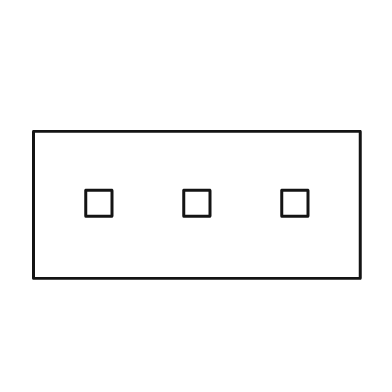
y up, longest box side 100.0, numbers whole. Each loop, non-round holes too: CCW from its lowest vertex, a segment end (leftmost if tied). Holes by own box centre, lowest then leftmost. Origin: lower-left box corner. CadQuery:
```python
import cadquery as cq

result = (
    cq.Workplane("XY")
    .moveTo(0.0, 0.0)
    .lineTo(100.0, 0.0)
    .lineTo(100.0, 45.0)
    .lineTo(0.0, 45.0)
    .close()
    .moveTo(16.0, 19.0)
    .lineTo(24.0, 19.0)
    .lineTo(24.0, 27.0)
    .lineTo(16.0, 27.0)
    .close()
    .moveTo(46.0, 19.0)
    .lineTo(54.0, 19.0)
    .lineTo(54.0, 27.0)
    .lineTo(46.0, 27.0)
    .close()
    .moveTo(76.0, 19.0)
    .lineTo(84.0, 19.0)
    .lineTo(84.0, 27.0)
    .lineTo(76.0, 27.0)
    .close()
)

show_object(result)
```